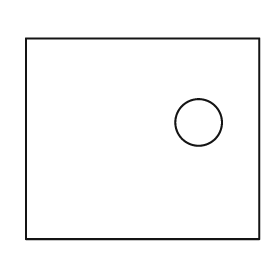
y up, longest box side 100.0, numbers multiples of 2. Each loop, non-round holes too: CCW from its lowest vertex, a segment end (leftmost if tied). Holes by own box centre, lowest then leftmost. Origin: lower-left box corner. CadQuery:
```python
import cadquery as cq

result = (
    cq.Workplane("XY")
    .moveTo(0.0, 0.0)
    .lineTo(100.0, 0.0)
    .lineTo(100.0, 86.0)
    .lineTo(0.0, 86.0)
    .close()
    .moveTo(74.0, 50.0)
    .circle(10.0)
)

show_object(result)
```